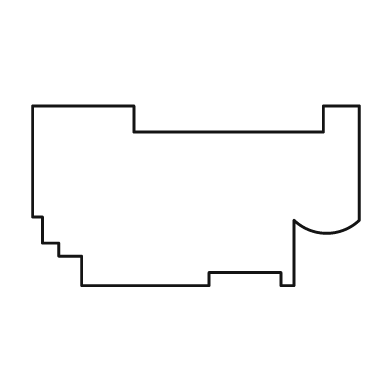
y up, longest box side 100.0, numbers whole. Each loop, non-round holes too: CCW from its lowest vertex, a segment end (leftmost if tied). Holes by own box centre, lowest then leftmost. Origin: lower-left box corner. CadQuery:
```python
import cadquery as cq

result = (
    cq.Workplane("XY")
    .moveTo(15.0, 0.0)
    .lineTo(54.0, 0.0)
    .lineTo(54.0, 4.0)
    .lineTo(76.0, 4.0)
    .lineTo(76.0, 0.0)
    .lineTo(80.0, 0.0)
    .lineTo(80.0, 20.0)
    .threePointArc((90.0, 16.0), (100.0, 20.0))
    .lineTo(100.0, 55.0)
    .lineTo(89.0, 55.0)
    .lineTo(89.0, 47.0)
    .lineTo(31.0, 47.0)
    .lineTo(31.0, 55.0)
    .lineTo(0.0, 55.0)
    .lineTo(0.0, 21.0)
    .lineTo(3.0, 21.0)
    .lineTo(3.0, 13.0)
    .lineTo(8.0, 13.0)
    .lineTo(8.0, 9.0)
    .lineTo(15.0, 9.0)
    .close()
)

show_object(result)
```